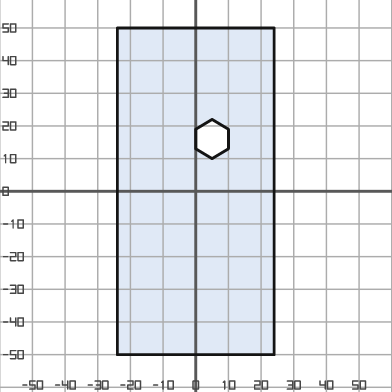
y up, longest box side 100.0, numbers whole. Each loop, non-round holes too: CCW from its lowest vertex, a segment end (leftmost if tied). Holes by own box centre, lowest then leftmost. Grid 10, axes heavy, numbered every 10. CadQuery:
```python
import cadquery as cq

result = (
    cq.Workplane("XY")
    .moveTo(-24.0, -50.0)
    .lineTo(24.0, -50.0)
    .lineTo(24.0, 50.0)
    .lineTo(-24.0, 50.0)
    .close()
    .moveTo(5.0, 10.0)
    .lineTo(10.0, 13.0)
    .lineTo(10.0, 19.0)
    .lineTo(5.0, 22.0)
    .lineTo(0.0, 19.0)
    .lineTo(0.0, 13.0)
    .close()
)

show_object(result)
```